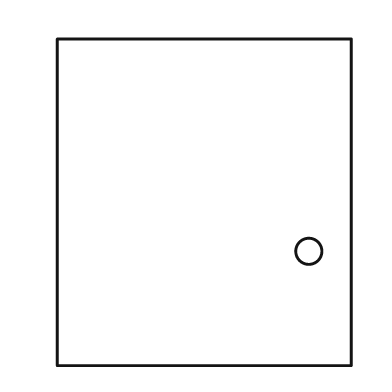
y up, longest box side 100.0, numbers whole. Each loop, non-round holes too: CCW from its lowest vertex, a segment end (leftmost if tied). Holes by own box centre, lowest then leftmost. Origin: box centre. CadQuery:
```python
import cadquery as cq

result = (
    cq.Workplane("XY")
    .moveTo(-45.0, -50.0)
    .lineTo(45.0, -50.0)
    .lineTo(45.0, 50.0)
    .lineTo(-45.0, 50.0)
    .close()
    .moveTo(32.0, -15.0)
    .circle(4.0)
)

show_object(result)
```